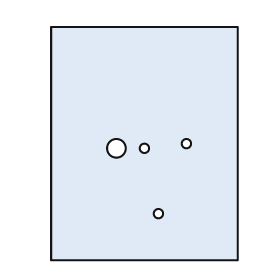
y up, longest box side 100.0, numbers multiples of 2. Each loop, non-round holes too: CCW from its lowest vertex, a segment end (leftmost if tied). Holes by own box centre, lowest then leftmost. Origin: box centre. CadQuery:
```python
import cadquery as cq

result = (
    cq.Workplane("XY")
    .moveTo(-40.0, -50.0)
    .lineTo(40.0, -50.0)
    .lineTo(40.0, 50.0)
    .lineTo(-40.0, 50.0)
    .close()
    .moveTo(6.0, -30.0)
    .circle(2.0)
    .moveTo(-12.0, -2.0)
    .circle(4.0)
    .moveTo(0.0, -2.0)
    .circle(2.0)
    .moveTo(18.0, 0.0)
    .circle(2.0)
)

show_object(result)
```